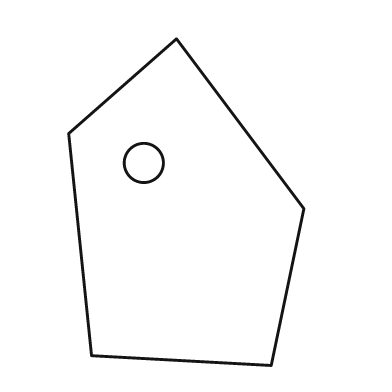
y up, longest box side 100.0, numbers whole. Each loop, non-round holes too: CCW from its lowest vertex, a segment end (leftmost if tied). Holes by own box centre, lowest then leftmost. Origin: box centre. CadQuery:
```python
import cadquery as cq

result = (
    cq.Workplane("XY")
    .moveTo(26.0, -50.0)
    .lineTo(36.0, -2.0)
    .lineTo(-3.0, 50.0)
    .lineTo(-36.0, 21.0)
    .lineTo(-29.0, -47.0)
    .close()
    .moveTo(-13.0, 12.0)
    .circle(6.0)
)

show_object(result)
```